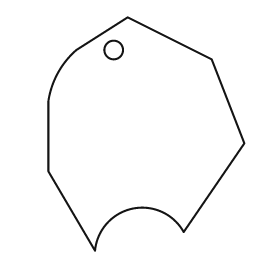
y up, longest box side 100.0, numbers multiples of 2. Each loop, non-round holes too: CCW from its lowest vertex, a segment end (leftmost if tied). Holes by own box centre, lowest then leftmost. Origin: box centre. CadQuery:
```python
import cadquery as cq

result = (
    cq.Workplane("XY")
    .moveTo(-22.0, -50.0)
    .threePointArc((-6.0, -32.0), (16.0, -42.0))
    .lineTo(42.0, -4.0)
    .lineTo(28.0, 32.0)
    .lineTo(-8.0, 50.0)
    .lineTo(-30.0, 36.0)
    .threePointArc((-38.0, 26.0), (-42.0, 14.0))
    .lineTo(-42.0, -16.0)
    .close()
    .moveTo(-14.0, 36.0)
    .circle(4.0)
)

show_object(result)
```